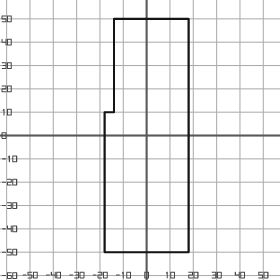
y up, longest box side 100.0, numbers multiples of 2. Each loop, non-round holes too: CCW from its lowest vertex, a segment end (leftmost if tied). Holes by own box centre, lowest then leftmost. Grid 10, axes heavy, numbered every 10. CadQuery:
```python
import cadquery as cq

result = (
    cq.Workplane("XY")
    .moveTo(-18.0, -50.0)
    .lineTo(18.0, -50.0)
    .lineTo(18.0, 50.0)
    .lineTo(-14.0, 50.0)
    .lineTo(-14.0, 10.0)
    .lineTo(-18.0, 10.0)
    .close()
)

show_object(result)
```